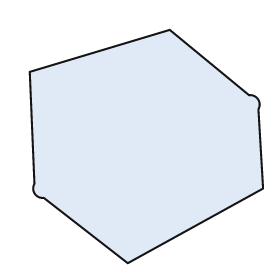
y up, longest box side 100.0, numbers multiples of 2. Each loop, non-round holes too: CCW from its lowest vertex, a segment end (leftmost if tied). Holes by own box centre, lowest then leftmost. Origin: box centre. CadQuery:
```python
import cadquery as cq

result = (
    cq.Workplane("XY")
    .moveTo(-8.0, -50.0)
    .lineTo(50.0, -18.0)
    .lineTo(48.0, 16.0)
    .threePointArc((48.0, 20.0), (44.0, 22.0))
    .lineTo(10.0, 50.0)
    .lineTo(-50.0, 32.0)
    .lineTo(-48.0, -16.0)
    .threePointArc((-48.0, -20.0), (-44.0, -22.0))
    .close()
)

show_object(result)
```